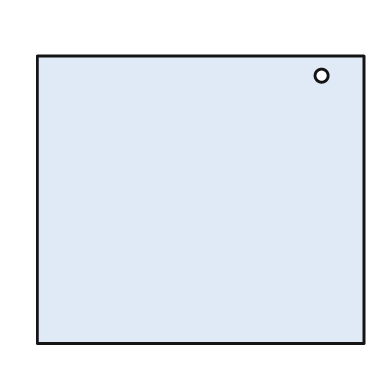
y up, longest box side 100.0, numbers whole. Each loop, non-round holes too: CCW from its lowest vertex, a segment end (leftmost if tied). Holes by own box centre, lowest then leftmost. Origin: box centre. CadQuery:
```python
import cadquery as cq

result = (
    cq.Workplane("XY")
    .moveTo(-50.0, -44.0)
    .lineTo(50.0, -44.0)
    .lineTo(50.0, 44.0)
    .lineTo(-50.0, 44.0)
    .close()
    .moveTo(37.0, 38.0)
    .circle(2.0)
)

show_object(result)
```